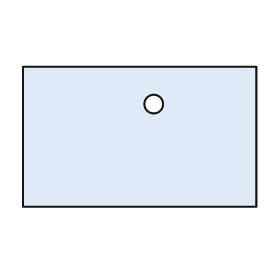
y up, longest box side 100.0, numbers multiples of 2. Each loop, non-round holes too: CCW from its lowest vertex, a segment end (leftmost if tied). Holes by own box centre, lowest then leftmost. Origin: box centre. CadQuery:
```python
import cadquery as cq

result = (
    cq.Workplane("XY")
    .moveTo(-50.0, -30.0)
    .lineTo(50.0, -30.0)
    .lineTo(50.0, 30.0)
    .lineTo(-50.0, 30.0)
    .close()
    .moveTo(6.0, 14.0)
    .circle(4.0)
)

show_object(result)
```